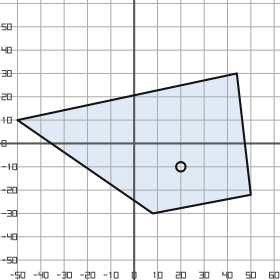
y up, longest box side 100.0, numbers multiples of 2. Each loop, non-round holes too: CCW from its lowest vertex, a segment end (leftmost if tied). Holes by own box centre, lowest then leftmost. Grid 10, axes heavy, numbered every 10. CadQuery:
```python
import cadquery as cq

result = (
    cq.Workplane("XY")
    .moveTo(8.0, -30.0)
    .lineTo(50.0, -22.0)
    .lineTo(44.0, 30.0)
    .lineTo(-50.0, 10.0)
    .close()
    .moveTo(20.0, -10.0)
    .circle(2.0)
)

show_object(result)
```